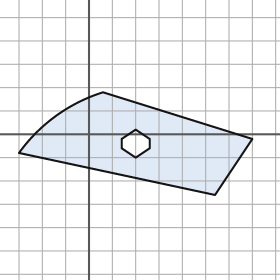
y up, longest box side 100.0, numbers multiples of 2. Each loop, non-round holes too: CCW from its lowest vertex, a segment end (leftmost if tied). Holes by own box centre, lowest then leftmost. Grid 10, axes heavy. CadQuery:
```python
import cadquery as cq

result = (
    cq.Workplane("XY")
    .moveTo(54.0, -26.0)
    .lineTo(70.0, -2.0)
    .lineTo(6.0, 18.0)
    .threePointArc((-14.0, 8.0), (-30.0, -8.0))
    .close()
    .moveTo(20.0, -10.0)
    .lineTo(26.0, -6.0)
    .lineTo(26.0, -2.0)
    .lineTo(20.0, 2.0)
    .lineTo(14.0, -2.0)
    .lineTo(14.0, -6.0)
    .close()
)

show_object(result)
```